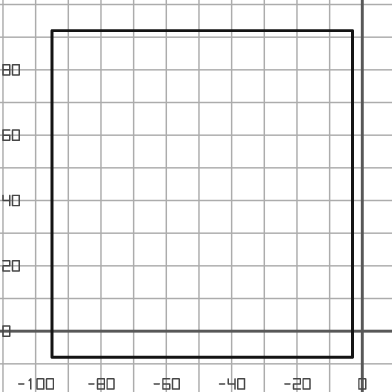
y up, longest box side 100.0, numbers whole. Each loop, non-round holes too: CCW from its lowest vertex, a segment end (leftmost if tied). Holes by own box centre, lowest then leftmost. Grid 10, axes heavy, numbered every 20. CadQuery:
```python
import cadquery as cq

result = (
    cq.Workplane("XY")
    .moveTo(-95.0, -8.0)
    .lineTo(-3.0, -8.0)
    .lineTo(-3.0, 92.0)
    .lineTo(-95.0, 92.0)
    .close()
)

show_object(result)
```